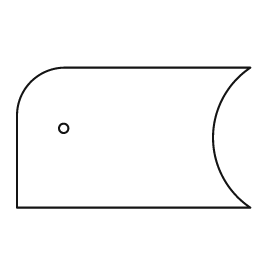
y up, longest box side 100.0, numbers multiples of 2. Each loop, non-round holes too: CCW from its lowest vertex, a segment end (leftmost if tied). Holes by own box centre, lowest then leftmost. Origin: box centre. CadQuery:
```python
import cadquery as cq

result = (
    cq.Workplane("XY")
    .moveTo(-50.0, -30.0)
    .lineTo(50.0, -30.0)
    .threePointArc((34.0, 0.0), (50.0, 30.0))
    .lineTo(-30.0, 30.0)
    .threePointArc((-44.0, 24.0), (-50.0, 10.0))
    .close()
    .moveTo(-30.0, 4.0)
    .circle(2.0)
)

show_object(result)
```